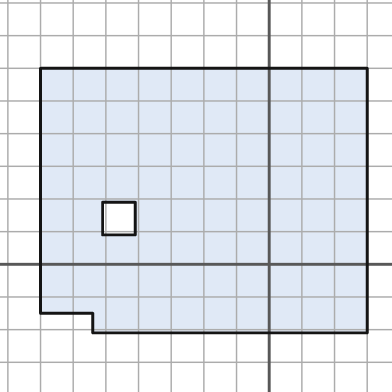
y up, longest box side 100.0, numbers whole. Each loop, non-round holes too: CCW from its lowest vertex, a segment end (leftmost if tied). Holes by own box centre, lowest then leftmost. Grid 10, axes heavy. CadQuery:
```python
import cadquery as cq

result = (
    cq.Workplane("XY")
    .moveTo(-54.0, -21.0)
    .lineTo(30.0, -21.0)
    .lineTo(30.0, 60.0)
    .lineTo(-70.0, 60.0)
    .lineTo(-70.0, -15.0)
    .lineTo(-54.0, -15.0)
    .close()
    .moveTo(-51.0, 9.0)
    .lineTo(-41.0, 9.0)
    .lineTo(-41.0, 19.0)
    .lineTo(-51.0, 19.0)
    .close()
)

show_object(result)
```